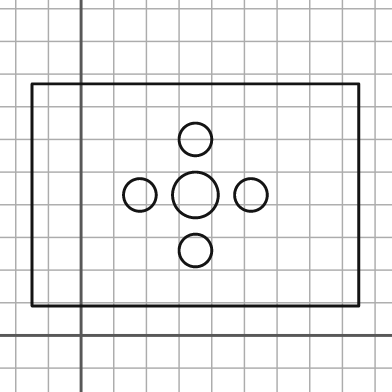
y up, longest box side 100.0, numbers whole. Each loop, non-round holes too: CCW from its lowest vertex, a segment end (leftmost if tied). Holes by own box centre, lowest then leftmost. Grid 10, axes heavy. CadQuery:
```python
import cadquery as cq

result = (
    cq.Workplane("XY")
    .moveTo(-15.0, 9.0)
    .lineTo(85.0, 9.0)
    .lineTo(85.0, 77.0)
    .lineTo(-15.0, 77.0)
    .close()
    .moveTo(35.0, 26.0)
    .circle(5.0)
    .moveTo(18.0, 43.0)
    .circle(5.0)
    .moveTo(35.0, 43.0)
    .circle(7.0)
    .moveTo(52.0, 43.0)
    .circle(5.0)
    .moveTo(35.0, 60.0)
    .circle(5.0)
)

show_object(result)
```